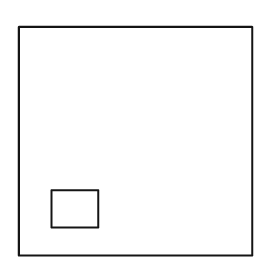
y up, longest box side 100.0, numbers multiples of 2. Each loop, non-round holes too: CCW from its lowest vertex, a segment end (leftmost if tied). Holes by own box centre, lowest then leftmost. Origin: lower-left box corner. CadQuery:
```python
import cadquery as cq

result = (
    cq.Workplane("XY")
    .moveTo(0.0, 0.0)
    .lineTo(100.0, 0.0)
    .lineTo(100.0, 98.0)
    .lineTo(0.0, 98.0)
    .close()
    .moveTo(14.0, 12.0)
    .lineTo(34.0, 12.0)
    .lineTo(34.0, 28.0)
    .lineTo(14.0, 28.0)
    .close()
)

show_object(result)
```